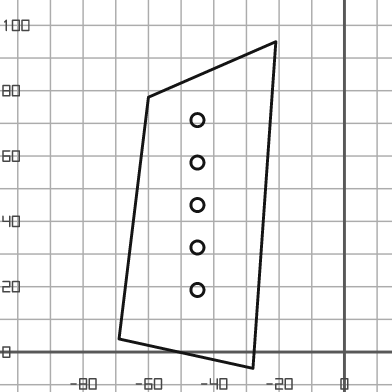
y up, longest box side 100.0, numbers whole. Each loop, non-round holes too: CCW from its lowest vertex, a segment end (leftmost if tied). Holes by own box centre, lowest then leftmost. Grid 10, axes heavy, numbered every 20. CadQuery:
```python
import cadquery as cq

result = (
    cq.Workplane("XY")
    .moveTo(-28.0, -5.0)
    .lineTo(-21.0, 95.0)
    .lineTo(-60.0, 78.0)
    .lineTo(-69.0, 4.0)
    .close()
    .moveTo(-45.0, 19.0)
    .circle(2.0)
    .moveTo(-45.0, 32.0)
    .circle(2.0)
    .moveTo(-45.0, 45.0)
    .circle(2.0)
    .moveTo(-45.0, 58.0)
    .circle(2.0)
    .moveTo(-45.0, 71.0)
    .circle(2.0)
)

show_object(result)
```